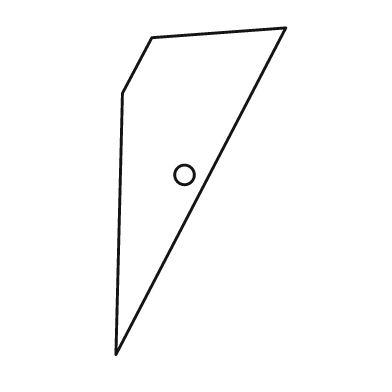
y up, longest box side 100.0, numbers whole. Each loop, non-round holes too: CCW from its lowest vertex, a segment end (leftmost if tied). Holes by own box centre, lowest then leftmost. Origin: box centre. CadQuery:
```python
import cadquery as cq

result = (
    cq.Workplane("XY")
    .moveTo(-26.0, -50.0)
    .lineTo(26.0, 50.0)
    .lineTo(-15.0, 47.0)
    .lineTo(-24.0, 30.0)
    .close()
    .moveTo(-5.0, 5.0)
    .circle(3.0)
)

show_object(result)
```